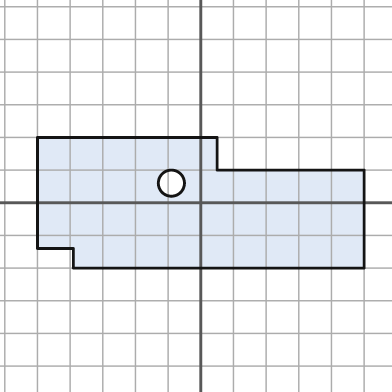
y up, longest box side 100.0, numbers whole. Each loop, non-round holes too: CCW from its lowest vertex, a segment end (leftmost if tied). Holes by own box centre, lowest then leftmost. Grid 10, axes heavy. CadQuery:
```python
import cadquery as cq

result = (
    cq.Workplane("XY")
    .moveTo(-39.0, -20.0)
    .lineTo(50.0, -20.0)
    .lineTo(50.0, 10.0)
    .lineTo(5.0, 10.0)
    .lineTo(5.0, 20.0)
    .lineTo(-50.0, 20.0)
    .lineTo(-50.0, -14.0)
    .lineTo(-39.0, -14.0)
    .close()
    .moveTo(-9.0, 6.0)
    .circle(4.0)
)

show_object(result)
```